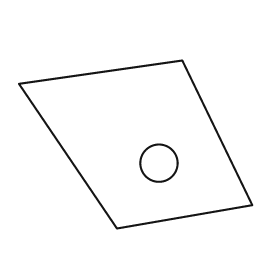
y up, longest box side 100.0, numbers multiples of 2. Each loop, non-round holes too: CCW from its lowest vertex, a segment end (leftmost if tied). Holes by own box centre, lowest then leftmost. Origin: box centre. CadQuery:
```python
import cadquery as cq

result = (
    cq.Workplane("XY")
    .moveTo(-8.0, -36.0)
    .lineTo(50.0, -26.0)
    .lineTo(20.0, 36.0)
    .lineTo(-50.0, 26.0)
    .close()
    .moveTo(10.0, -8.0)
    .circle(8.0)
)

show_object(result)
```